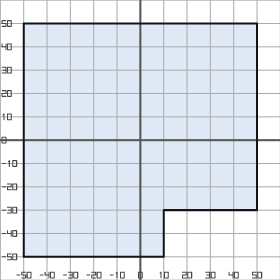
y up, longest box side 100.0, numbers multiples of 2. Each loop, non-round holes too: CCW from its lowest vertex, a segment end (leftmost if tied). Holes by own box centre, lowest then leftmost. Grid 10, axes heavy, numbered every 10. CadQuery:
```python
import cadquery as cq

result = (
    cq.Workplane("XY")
    .moveTo(-50.0, -50.0)
    .lineTo(10.0, -50.0)
    .lineTo(10.0, -30.0)
    .lineTo(50.0, -30.0)
    .lineTo(50.0, 50.0)
    .lineTo(-50.0, 50.0)
    .close()
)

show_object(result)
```